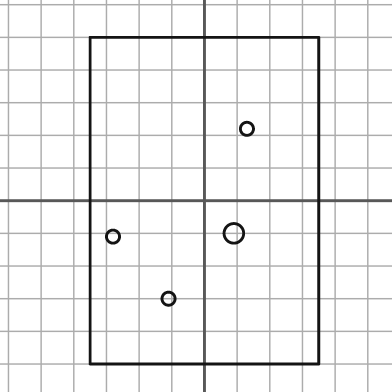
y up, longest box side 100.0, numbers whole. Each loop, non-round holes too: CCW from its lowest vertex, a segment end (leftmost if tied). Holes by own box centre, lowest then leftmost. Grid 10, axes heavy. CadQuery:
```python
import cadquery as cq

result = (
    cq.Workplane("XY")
    .moveTo(-35.0, -50.0)
    .lineTo(35.0, -50.0)
    .lineTo(35.0, 50.0)
    .lineTo(-35.0, 50.0)
    .close()
    .moveTo(-11.0, -30.0)
    .circle(2.0)
    .moveTo(-28.0, -11.0)
    .circle(2.0)
    .moveTo(9.0, -10.0)
    .circle(3.0)
    .moveTo(13.0, 22.0)
    .circle(2.0)
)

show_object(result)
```